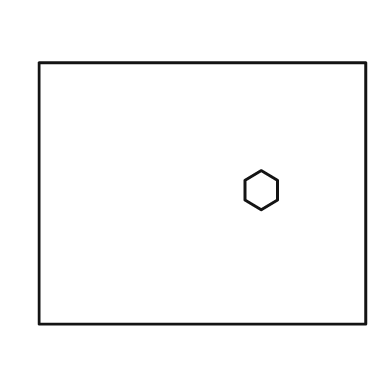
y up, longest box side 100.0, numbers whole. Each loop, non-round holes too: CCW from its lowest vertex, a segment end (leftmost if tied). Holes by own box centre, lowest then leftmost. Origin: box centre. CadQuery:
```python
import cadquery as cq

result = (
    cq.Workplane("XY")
    .moveTo(-50.0, -40.0)
    .lineTo(50.0, -40.0)
    .lineTo(50.0, 40.0)
    .lineTo(-50.0, 40.0)
    .close()
    .moveTo(18.0, -5.0)
    .lineTo(23.0, -2.0)
    .lineTo(23.0, 4.0)
    .lineTo(18.0, 7.0)
    .lineTo(13.0, 4.0)
    .lineTo(13.0, -2.0)
    .close()
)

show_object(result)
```